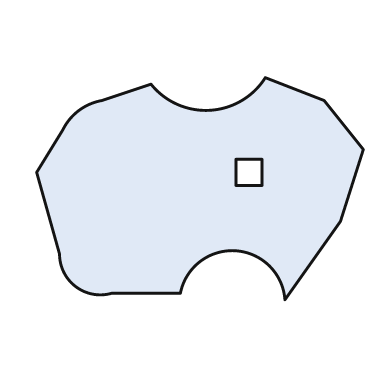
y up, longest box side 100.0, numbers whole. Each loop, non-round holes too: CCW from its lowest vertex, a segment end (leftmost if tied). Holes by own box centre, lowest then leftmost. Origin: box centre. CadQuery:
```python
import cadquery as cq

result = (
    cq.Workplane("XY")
    .moveTo(26.0, -34.0)
    .lineTo(43.0, -10.0)
    .lineTo(50.0, 12.0)
    .lineTo(38.0, 27.0)
    .lineTo(20.0, 34.0)
    .threePointArc((3.0, 24.0), (-15.0, 32.0))
    .lineTo(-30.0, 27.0)
    .threePointArc((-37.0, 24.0), (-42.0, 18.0))
    .lineTo(-50.0, 5.0)
    .lineTo(-43.0, -20.0)
    .threePointArc((-38.0, -30.0), (-27.0, -32.0))
    .lineTo(-6.0, -32.0)
    .threePointArc((11.0, -19.0), (26.0, -34.0))
    .close()
    .moveTo(11.0, 1.0)
    .lineTo(19.0, 1.0)
    .lineTo(19.0, 9.0)
    .lineTo(11.0, 9.0)
    .close()
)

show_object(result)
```